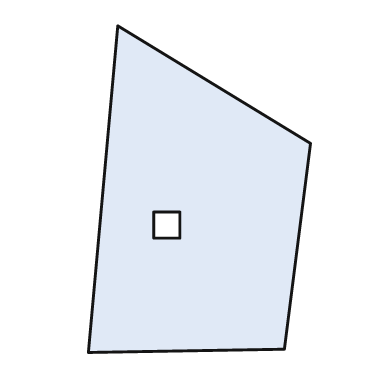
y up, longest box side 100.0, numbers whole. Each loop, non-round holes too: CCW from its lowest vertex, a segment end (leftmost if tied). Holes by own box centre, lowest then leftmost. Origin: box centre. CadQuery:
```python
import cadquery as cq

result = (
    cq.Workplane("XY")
    .moveTo(-34.0, -50.0)
    .lineTo(26.0, -49.0)
    .lineTo(34.0, 14.0)
    .lineTo(-25.0, 50.0)
    .close()
    .moveTo(-14.0, -15.0)
    .lineTo(-6.0, -15.0)
    .lineTo(-6.0, -7.0)
    .lineTo(-14.0, -7.0)
    .close()
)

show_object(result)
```